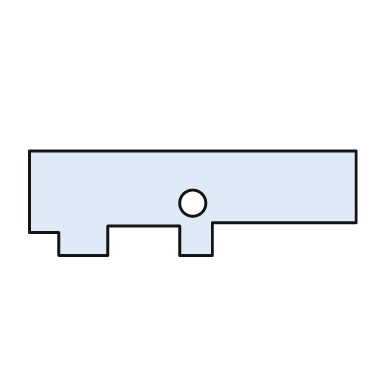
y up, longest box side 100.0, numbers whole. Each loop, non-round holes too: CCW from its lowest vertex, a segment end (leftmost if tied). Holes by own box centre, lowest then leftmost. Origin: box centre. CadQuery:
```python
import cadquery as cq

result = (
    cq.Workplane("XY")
    .moveTo(-41.0, -16.0)
    .lineTo(-26.0, -16.0)
    .lineTo(-26.0, -7.0)
    .lineTo(-4.0, -7.0)
    .lineTo(-4.0, -16.0)
    .lineTo(6.0, -16.0)
    .lineTo(6.0, -6.0)
    .lineTo(50.0, -6.0)
    .lineTo(50.0, 16.0)
    .lineTo(-50.0, 16.0)
    .lineTo(-50.0, -9.0)
    .lineTo(-41.0, -9.0)
    .close()
    .moveTo(0.0, 0.0)
    .circle(4.0)
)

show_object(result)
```